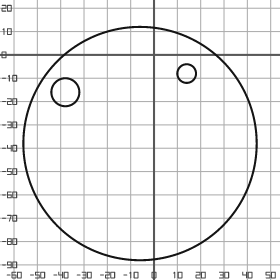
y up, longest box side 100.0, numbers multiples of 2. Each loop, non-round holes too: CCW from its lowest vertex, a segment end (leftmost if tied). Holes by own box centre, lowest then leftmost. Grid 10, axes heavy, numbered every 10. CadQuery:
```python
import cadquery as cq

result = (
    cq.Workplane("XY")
    .moveTo(-6.0, -38.0)
    .circle(50.0)
    .moveTo(-38.0, -16.0)
    .circle(6.0)
    .moveTo(14.0, -8.0)
    .circle(4.0)
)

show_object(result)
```